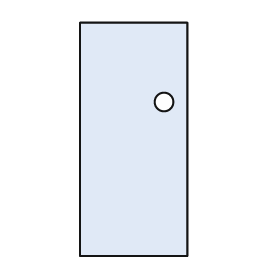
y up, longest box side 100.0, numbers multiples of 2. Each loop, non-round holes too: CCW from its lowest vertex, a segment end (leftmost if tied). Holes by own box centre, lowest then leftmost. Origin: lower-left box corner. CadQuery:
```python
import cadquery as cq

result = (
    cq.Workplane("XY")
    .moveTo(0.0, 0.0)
    .lineTo(46.0, 0.0)
    .lineTo(46.0, 100.0)
    .lineTo(0.0, 100.0)
    .close()
    .moveTo(36.0, 66.0)
    .circle(4.0)
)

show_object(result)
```